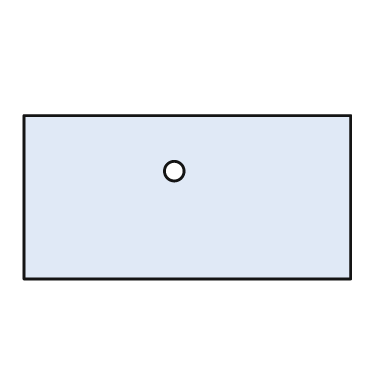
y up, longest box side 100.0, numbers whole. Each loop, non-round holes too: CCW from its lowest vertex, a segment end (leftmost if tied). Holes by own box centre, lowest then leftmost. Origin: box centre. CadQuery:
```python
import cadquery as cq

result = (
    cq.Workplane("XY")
    .moveTo(-50.0, -25.0)
    .lineTo(50.0, -25.0)
    .lineTo(50.0, 25.0)
    .lineTo(-50.0, 25.0)
    .close()
    .moveTo(-4.0, 8.0)
    .circle(3.0)
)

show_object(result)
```